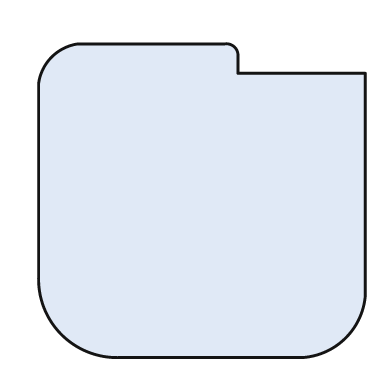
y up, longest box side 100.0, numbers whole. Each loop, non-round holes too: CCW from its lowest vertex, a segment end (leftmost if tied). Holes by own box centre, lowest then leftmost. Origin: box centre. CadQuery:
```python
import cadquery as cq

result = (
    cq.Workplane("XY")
    .moveTo(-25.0, -48.0)
    .lineTo(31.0, -48.0)
    .threePointArc((44.0, -42.0), (50.0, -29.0))
    .lineTo(50.0, 39.0)
    .lineTo(11.0, 39.0)
    .lineTo(11.0, 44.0)
    .threePointArc((10.0, 47.0), (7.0, 48.0))
    .lineTo(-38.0, 48.0)
    .threePointArc((-46.0, 44.0), (-50.0, 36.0))
    .lineTo(-50.0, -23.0)
    .threePointArc((-43.0, -41.0), (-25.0, -48.0))
    .close()
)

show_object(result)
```